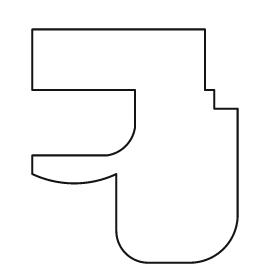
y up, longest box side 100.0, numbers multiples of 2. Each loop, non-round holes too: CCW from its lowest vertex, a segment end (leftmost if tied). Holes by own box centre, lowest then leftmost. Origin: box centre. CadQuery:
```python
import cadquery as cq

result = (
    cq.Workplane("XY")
    .moveTo(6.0, -50.0)
    .lineTo(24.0, -50.0)
    .threePointArc((38.0, -44.0), (44.0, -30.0))
    .lineTo(44.0, 16.0)
    .lineTo(34.0, 16.0)
    .lineTo(34.0, 24.0)
    .lineTo(30.0, 24.0)
    .lineTo(30.0, 50.0)
    .lineTo(-44.0, 50.0)
    .lineTo(-44.0, 24.0)
    .lineTo(0.0, 24.0)
    .lineTo(0.0, 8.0)
    .threePointArc((-4.0, 0.0), (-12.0, -4.0))
    .lineTo(-44.0, -4.0)
    .lineTo(-44.0, -12.0)
    .threePointArc((-26.0, -16.0), (-8.0, -12.0))
    .lineTo(-8.0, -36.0)
    .threePointArc((-4.0, -46.0), (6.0, -50.0))
    .close()
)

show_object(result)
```